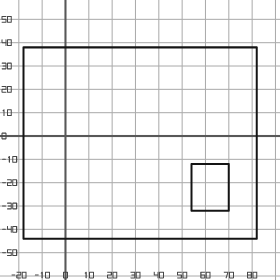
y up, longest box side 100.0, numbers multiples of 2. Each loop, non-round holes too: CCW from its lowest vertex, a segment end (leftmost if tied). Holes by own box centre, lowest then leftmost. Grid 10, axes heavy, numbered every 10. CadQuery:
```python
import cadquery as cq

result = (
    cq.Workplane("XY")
    .moveTo(-18.0, -44.0)
    .lineTo(82.0, -44.0)
    .lineTo(82.0, 38.0)
    .lineTo(-18.0, 38.0)
    .close()
    .moveTo(54.0, -32.0)
    .lineTo(70.0, -32.0)
    .lineTo(70.0, -12.0)
    .lineTo(54.0, -12.0)
    .close()
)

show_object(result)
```